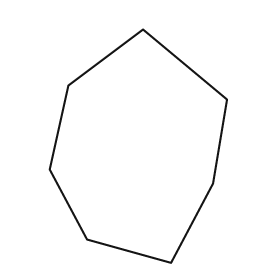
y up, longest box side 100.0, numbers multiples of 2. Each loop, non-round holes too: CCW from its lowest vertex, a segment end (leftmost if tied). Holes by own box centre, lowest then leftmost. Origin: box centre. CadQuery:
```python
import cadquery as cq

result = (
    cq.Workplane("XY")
    .moveTo(14.0, -50.0)
    .lineTo(32.0, -16.0)
    .lineTo(38.0, 20.0)
    .lineTo(2.0, 50.0)
    .lineTo(-30.0, 26.0)
    .lineTo(-38.0, -10.0)
    .lineTo(-22.0, -40.0)
    .close()
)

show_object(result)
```